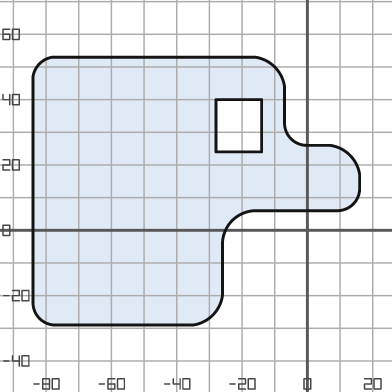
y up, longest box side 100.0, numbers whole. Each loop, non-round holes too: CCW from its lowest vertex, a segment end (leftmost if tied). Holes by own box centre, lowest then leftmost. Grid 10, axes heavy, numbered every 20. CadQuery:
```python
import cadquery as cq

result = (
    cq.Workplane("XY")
    .moveTo(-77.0, -29.0)
    .lineTo(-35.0, -29.0)
    .threePointArc((-29.0, -26.0), (-26.0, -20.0))
    .lineTo(-26.0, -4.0)
    .threePointArc((-23.0, 3.0), (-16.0, 6.0))
    .lineTo(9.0, 6.0)
    .threePointArc((14.0, 8.0), (16.0, 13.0))
    .lineTo(16.0, 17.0)
    .threePointArc((13.0, 23.0), (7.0, 26.0))
    .lineTo(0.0, 26.0)
    .threePointArc((-5.0, 28.0), (-7.0, 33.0))
    .lineTo(-7.0, 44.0)
    .threePointArc((-10.0, 50.0), (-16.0, 53.0))
    .lineTo(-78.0, 53.0)
    .threePointArc((-82.0, 51.0), (-84.0, 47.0))
    .lineTo(-84.0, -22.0)
    .threePointArc((-82.0, -27.0), (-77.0, -29.0))
    .close()
    .moveTo(-28.0, 24.0)
    .lineTo(-14.0, 24.0)
    .lineTo(-14.0, 40.0)
    .lineTo(-28.0, 40.0)
    .close()
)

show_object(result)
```